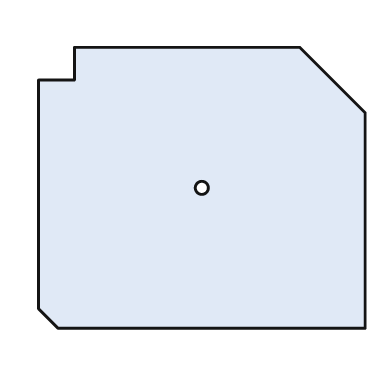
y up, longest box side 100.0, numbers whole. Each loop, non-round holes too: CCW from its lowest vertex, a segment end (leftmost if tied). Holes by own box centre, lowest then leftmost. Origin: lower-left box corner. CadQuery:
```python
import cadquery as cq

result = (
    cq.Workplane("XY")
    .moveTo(6.0, 0.0)
    .lineTo(100.0, 0.0)
    .lineTo(100.0, 66.0)
    .lineTo(80.0, 86.0)
    .lineTo(11.0, 86.0)
    .lineTo(11.0, 76.0)
    .lineTo(0.0, 76.0)
    .lineTo(0.0, 6.0)
    .close()
    .moveTo(50.0, 43.0)
    .circle(2.0)
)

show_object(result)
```